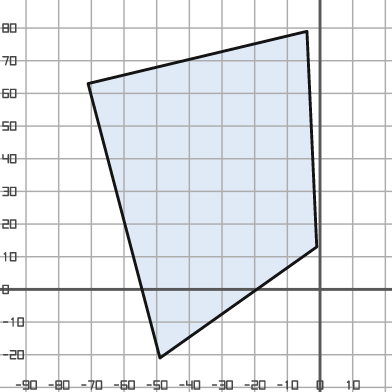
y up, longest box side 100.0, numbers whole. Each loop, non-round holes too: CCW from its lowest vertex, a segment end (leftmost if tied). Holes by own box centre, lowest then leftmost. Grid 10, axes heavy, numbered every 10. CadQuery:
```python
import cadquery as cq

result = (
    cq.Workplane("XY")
    .moveTo(-49.0, -21.0)
    .lineTo(-1.0, 13.0)
    .lineTo(-4.0, 79.0)
    .lineTo(-71.0, 63.0)
    .close()
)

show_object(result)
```